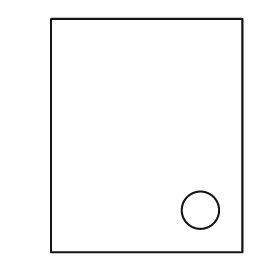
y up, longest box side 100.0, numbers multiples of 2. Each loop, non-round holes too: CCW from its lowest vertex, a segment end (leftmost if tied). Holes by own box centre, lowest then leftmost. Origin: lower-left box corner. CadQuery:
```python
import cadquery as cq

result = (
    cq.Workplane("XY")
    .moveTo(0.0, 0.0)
    .lineTo(82.0, 0.0)
    .lineTo(82.0, 100.0)
    .lineTo(0.0, 100.0)
    .close()
    .moveTo(64.0, 18.0)
    .circle(8.0)
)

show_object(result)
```